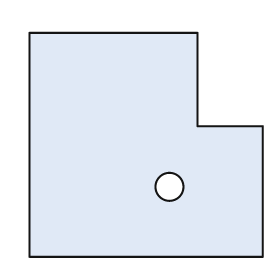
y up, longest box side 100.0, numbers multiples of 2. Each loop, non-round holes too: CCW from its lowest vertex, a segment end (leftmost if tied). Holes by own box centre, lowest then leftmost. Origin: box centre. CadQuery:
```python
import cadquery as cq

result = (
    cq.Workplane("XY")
    .moveTo(-50.0, -48.0)
    .lineTo(50.0, -48.0)
    .lineTo(50.0, 8.0)
    .lineTo(22.0, 8.0)
    .lineTo(22.0, 48.0)
    .lineTo(-50.0, 48.0)
    .close()
    .moveTo(10.0, -18.0)
    .circle(6.0)
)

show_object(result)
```